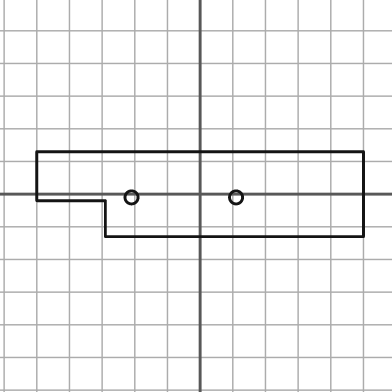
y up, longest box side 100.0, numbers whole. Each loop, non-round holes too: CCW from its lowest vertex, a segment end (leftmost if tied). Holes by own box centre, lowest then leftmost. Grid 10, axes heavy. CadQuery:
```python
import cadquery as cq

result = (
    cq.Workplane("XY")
    .moveTo(-29.0, -13.0)
    .lineTo(50.0, -13.0)
    .lineTo(50.0, 13.0)
    .lineTo(-50.0, 13.0)
    .lineTo(-50.0, -2.0)
    .lineTo(-29.0, -2.0)
    .close()
    .moveTo(-21.0, -1.0)
    .circle(2.0)
    .moveTo(11.0, -1.0)
    .circle(2.0)
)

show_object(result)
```